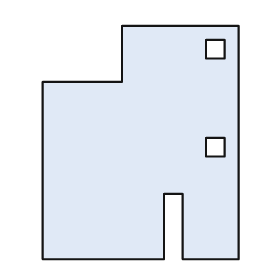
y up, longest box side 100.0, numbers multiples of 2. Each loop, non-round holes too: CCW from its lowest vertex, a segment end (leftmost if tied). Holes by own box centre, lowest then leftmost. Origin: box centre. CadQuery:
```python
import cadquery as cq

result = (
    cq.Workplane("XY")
    .moveTo(-42.0, -50.0)
    .lineTo(10.0, -50.0)
    .lineTo(10.0, -22.0)
    .lineTo(18.0, -22.0)
    .lineTo(18.0, -50.0)
    .lineTo(42.0, -50.0)
    .lineTo(42.0, 50.0)
    .lineTo(-8.0, 50.0)
    .lineTo(-8.0, 26.0)
    .lineTo(-42.0, 26.0)
    .close()
    .moveTo(28.0, -6.0)
    .lineTo(36.0, -6.0)
    .lineTo(36.0, 2.0)
    .lineTo(28.0, 2.0)
    .close()
    .moveTo(28.0, 36.0)
    .lineTo(36.0, 36.0)
    .lineTo(36.0, 44.0)
    .lineTo(28.0, 44.0)
    .close()
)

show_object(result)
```